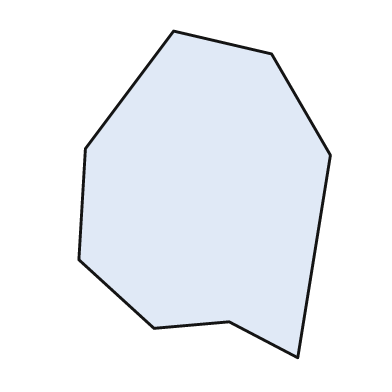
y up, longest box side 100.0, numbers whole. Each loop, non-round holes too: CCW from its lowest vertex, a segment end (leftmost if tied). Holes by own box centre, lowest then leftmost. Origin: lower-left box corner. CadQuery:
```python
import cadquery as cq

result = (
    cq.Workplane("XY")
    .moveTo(67.0, 0.0)
    .lineTo(77.0, 62.0)
    .lineTo(59.0, 93.0)
    .lineTo(29.0, 100.0)
    .lineTo(2.0, 64.0)
    .lineTo(0.0, 30.0)
    .lineTo(23.0, 9.0)
    .lineTo(46.0, 11.0)
    .close()
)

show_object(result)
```